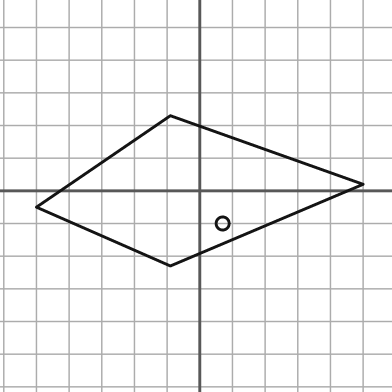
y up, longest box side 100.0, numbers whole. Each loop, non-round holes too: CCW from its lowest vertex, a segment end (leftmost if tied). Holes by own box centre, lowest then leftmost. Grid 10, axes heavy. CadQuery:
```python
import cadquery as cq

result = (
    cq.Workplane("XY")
    .moveTo(-9.0, -23.0)
    .lineTo(50.0, 2.0)
    .lineTo(-9.0, 23.0)
    .lineTo(-50.0, -5.0)
    .close()
    .moveTo(7.0, -10.0)
    .circle(2.0)
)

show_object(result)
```